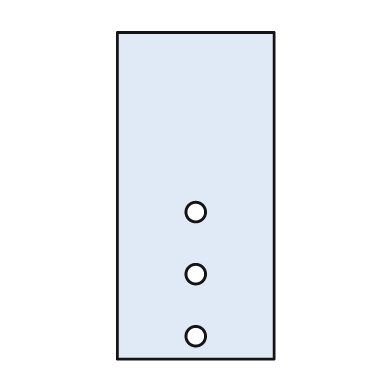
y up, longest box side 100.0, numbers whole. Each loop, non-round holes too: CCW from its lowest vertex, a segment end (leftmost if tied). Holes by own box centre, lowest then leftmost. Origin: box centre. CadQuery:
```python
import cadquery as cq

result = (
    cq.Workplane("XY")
    .moveTo(-24.0, -50.0)
    .lineTo(24.0, -50.0)
    .lineTo(24.0, 50.0)
    .lineTo(-24.0, 50.0)
    .close()
    .moveTo(0.0, -43.0)
    .circle(3.0)
    .moveTo(0.0, -24.0)
    .circle(3.0)
    .moveTo(0.0, -5.0)
    .circle(3.0)
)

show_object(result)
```